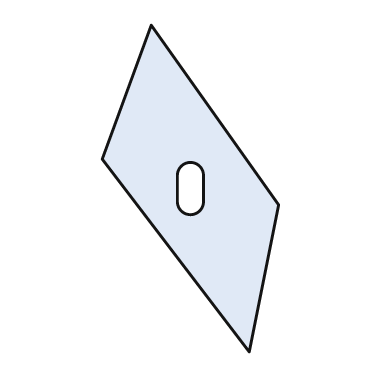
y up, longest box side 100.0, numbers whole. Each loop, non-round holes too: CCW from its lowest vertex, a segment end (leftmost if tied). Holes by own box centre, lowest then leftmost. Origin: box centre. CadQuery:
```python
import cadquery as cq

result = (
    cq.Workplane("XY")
    .moveTo(18.0, -50.0)
    .lineTo(27.0, -5.0)
    .lineTo(-12.0, 50.0)
    .lineTo(-27.0, 9.0)
    .close()
    .moveTo(-4.0, -4.0)
    .threePointArc((0.0, -8.0), (4.0, -4.0))
    .lineTo(4.0, 4.0)
    .threePointArc((0.0, 8.0), (-4.0, 4.0))
    .close()
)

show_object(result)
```